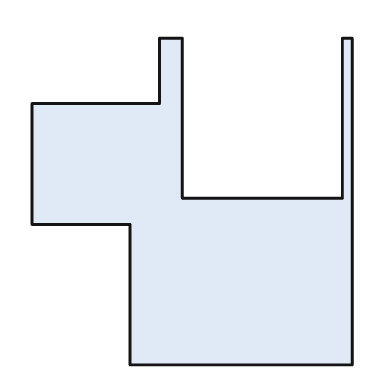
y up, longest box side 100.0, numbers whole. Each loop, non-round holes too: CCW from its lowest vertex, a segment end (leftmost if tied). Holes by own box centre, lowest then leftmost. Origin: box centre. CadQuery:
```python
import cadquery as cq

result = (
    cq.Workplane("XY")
    .moveTo(-19.0, -50.0)
    .lineTo(49.0, -50.0)
    .lineTo(49.0, 50.0)
    .lineTo(46.0, 50.0)
    .lineTo(46.0, 1.0)
    .lineTo(-3.0, 1.0)
    .lineTo(-3.0, 50.0)
    .lineTo(-10.0, 50.0)
    .lineTo(-10.0, 30.0)
    .lineTo(-49.0, 30.0)
    .lineTo(-49.0, -7.0)
    .lineTo(-19.0, -7.0)
    .close()
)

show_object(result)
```